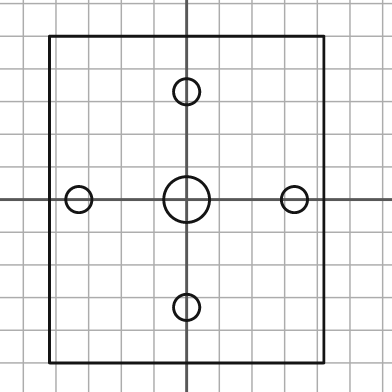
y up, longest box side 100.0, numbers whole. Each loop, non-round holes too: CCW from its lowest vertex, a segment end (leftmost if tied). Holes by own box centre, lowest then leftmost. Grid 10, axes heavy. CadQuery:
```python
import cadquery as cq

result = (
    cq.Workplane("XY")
    .moveTo(-42.0, -50.0)
    .lineTo(42.0, -50.0)
    .lineTo(42.0, 50.0)
    .lineTo(-42.0, 50.0)
    .close()
    .moveTo(0.0, -33.0)
    .circle(4.0)
    .moveTo(-33.0, 0.0)
    .circle(4.0)
    .moveTo(0.0, 0.0)
    .circle(7.0)
    .moveTo(33.0, 0.0)
    .circle(4.0)
    .moveTo(0.0, 33.0)
    .circle(4.0)
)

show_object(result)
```